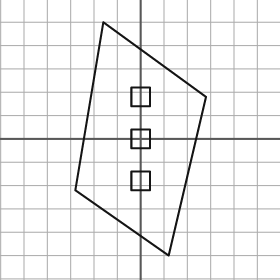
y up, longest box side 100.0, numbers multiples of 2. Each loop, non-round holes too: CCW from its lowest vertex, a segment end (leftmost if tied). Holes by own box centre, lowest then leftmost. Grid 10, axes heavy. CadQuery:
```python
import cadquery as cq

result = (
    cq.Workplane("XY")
    .moveTo(12.0, -50.0)
    .lineTo(28.0, 18.0)
    .lineTo(-16.0, 50.0)
    .lineTo(-28.0, -22.0)
    .close()
    .moveTo(-4.0, -22.0)
    .lineTo(4.0, -22.0)
    .lineTo(4.0, -14.0)
    .lineTo(-4.0, -14.0)
    .close()
    .moveTo(-4.0, -4.0)
    .lineTo(4.0, -4.0)
    .lineTo(4.0, 4.0)
    .lineTo(-4.0, 4.0)
    .close()
    .moveTo(-4.0, 14.0)
    .lineTo(4.0, 14.0)
    .lineTo(4.0, 22.0)
    .lineTo(-4.0, 22.0)
    .close()
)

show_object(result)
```